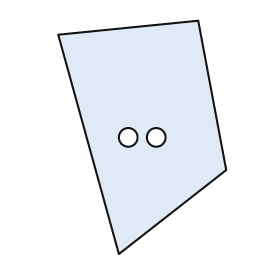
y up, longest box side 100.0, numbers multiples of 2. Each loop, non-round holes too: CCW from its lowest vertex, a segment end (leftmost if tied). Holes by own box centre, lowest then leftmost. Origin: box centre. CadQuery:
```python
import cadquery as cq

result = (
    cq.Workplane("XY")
    .moveTo(-10.0, -50.0)
    .lineTo(36.0, -14.0)
    .lineTo(24.0, 50.0)
    .lineTo(-36.0, 44.0)
    .close()
    .moveTo(-6.0, 0.0)
    .circle(4.0)
    .moveTo(6.0, 0.0)
    .circle(4.0)
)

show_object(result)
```